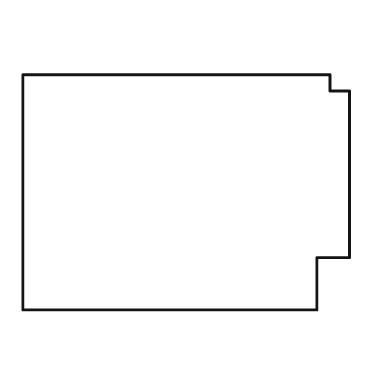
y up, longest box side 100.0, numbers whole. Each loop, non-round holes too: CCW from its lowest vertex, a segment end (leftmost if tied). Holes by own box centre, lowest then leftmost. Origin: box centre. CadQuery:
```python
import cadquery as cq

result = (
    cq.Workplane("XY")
    .moveTo(-50.0, -36.0)
    .lineTo(40.0, -36.0)
    .lineTo(40.0, -20.0)
    .lineTo(50.0, -20.0)
    .lineTo(50.0, 31.0)
    .lineTo(44.0, 31.0)
    .lineTo(44.0, 36.0)
    .lineTo(-50.0, 36.0)
    .close()
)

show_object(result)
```